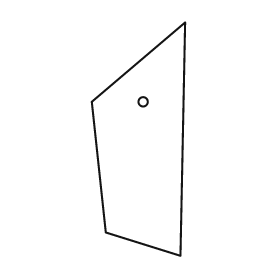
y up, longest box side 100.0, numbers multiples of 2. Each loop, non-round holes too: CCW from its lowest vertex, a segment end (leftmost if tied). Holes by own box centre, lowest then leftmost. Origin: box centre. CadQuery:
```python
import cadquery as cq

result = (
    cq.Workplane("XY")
    .moveTo(18.0, -50.0)
    .lineTo(20.0, 50.0)
    .lineTo(-20.0, 16.0)
    .lineTo(-14.0, -40.0)
    .close()
    .moveTo(2.0, 16.0)
    .circle(2.0)
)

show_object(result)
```